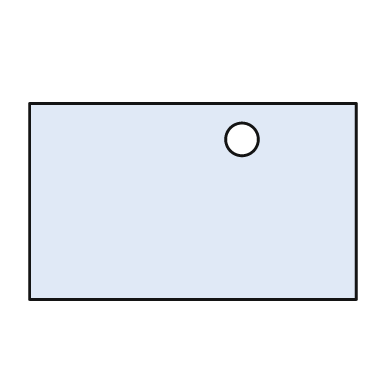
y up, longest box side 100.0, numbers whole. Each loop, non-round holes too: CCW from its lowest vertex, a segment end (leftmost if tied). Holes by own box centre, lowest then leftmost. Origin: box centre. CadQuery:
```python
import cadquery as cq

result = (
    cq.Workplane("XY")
    .moveTo(-50.0, -30.0)
    .lineTo(50.0, -30.0)
    .lineTo(50.0, 30.0)
    .lineTo(-50.0, 30.0)
    .close()
    .moveTo(15.0, 19.0)
    .circle(5.0)
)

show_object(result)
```